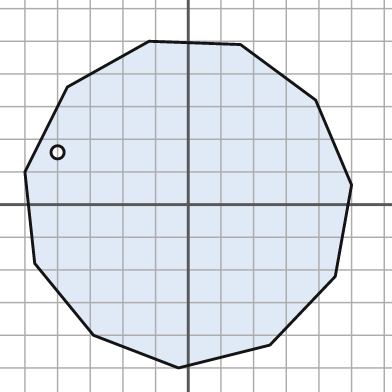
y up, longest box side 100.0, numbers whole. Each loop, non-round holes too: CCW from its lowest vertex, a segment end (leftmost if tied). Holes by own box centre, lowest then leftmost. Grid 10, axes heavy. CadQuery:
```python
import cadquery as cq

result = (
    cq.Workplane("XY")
    .moveTo(-3.0, -50.0)
    .lineTo(25.0, -43.0)
    .lineTo(45.0, -22.0)
    .lineTo(50.0, 6.0)
    .lineTo(39.0, 32.0)
    .lineTo(16.0, 49.0)
    .lineTo(-12.0, 50.0)
    .lineTo(-37.0, 36.0)
    .lineTo(-50.0, 10.0)
    .lineTo(-47.0, -18.0)
    .lineTo(-29.0, -40.0)
    .close()
    .moveTo(-40.0, 16.0)
    .circle(2.0)
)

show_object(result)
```